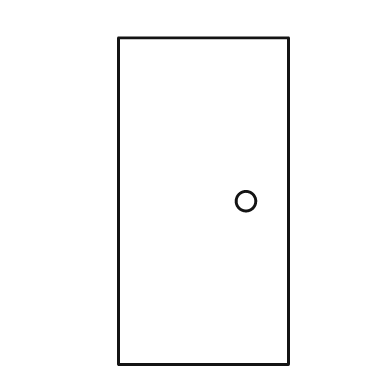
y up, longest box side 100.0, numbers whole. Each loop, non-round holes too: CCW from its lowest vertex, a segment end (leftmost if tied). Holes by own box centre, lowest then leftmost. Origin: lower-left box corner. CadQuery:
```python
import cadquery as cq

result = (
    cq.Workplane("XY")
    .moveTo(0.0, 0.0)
    .lineTo(52.0, 0.0)
    .lineTo(52.0, 100.0)
    .lineTo(0.0, 100.0)
    .close()
    .moveTo(39.0, 50.0)
    .circle(3.0)
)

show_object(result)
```